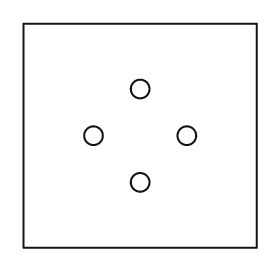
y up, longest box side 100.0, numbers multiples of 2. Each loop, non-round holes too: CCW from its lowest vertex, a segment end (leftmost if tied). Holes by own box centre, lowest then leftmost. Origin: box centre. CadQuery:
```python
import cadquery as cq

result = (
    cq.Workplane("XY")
    .moveTo(-50.0, -48.0)
    .lineTo(50.0, -48.0)
    .lineTo(50.0, 48.0)
    .lineTo(-50.0, 48.0)
    .close()
    .moveTo(0.0, -20.0)
    .circle(4.0)
    .moveTo(-20.0, 0.0)
    .circle(4.0)
    .moveTo(20.0, 0.0)
    .circle(4.0)
    .moveTo(0.0, 20.0)
    .circle(4.0)
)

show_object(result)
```